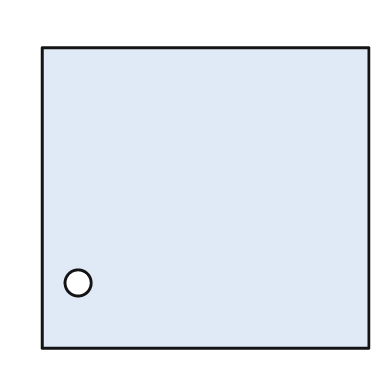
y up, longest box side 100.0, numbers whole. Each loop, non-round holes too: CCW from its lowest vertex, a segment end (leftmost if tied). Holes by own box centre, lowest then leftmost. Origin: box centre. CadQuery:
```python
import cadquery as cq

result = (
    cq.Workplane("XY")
    .moveTo(-50.0, -46.0)
    .lineTo(50.0, -46.0)
    .lineTo(50.0, 46.0)
    .lineTo(-50.0, 46.0)
    .close()
    .moveTo(-39.0, -26.0)
    .circle(4.0)
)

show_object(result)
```